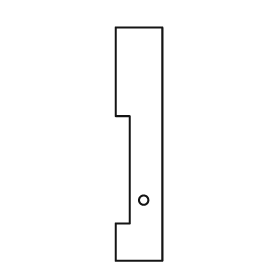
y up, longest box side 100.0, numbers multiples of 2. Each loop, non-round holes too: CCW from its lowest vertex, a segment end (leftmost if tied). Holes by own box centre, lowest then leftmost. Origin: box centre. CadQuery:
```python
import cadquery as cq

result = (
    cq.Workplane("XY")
    .moveTo(-10.0, -50.0)
    .lineTo(10.0, -50.0)
    .lineTo(10.0, 50.0)
    .lineTo(-10.0, 50.0)
    .lineTo(-10.0, 12.0)
    .lineTo(-4.0, 12.0)
    .lineTo(-4.0, -34.0)
    .lineTo(-10.0, -34.0)
    .close()
    .moveTo(2.0, -24.0)
    .circle(2.0)
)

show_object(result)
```